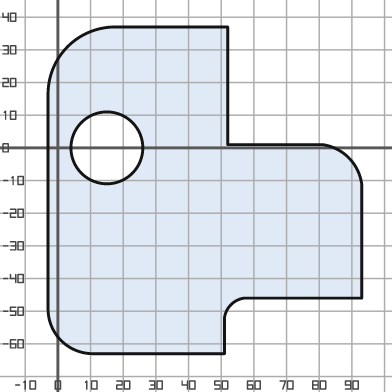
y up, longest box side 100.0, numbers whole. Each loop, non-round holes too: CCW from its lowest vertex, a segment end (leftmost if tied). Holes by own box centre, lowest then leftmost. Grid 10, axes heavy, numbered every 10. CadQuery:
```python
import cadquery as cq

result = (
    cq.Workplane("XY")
    .moveTo(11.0, -63.0)
    .lineTo(51.0, -63.0)
    .lineTo(51.0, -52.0)
    .threePointArc((53.0, -48.0), (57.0, -46.0))
    .lineTo(93.0, -46.0)
    .lineTo(93.0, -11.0)
    .threePointArc((89.0, -3.0), (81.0, 1.0))
    .lineTo(52.0, 1.0)
    .lineTo(52.0, 37.0)
    .lineTo(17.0, 37.0)
    .threePointArc((3.0, 31.0), (-3.0, 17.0))
    .lineTo(-3.0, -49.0)
    .threePointArc((1.0, -59.0), (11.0, -63.0))
    .close()
    .moveTo(15.0, 0.0)
    .circle(11.0)
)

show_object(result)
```